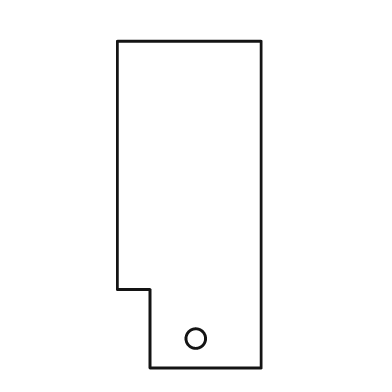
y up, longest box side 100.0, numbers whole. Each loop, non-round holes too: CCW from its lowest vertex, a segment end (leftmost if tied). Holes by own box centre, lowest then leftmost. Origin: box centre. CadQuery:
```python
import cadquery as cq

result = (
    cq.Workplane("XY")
    .moveTo(-12.0, -50.0)
    .lineTo(22.0, -50.0)
    .lineTo(22.0, 50.0)
    .lineTo(-22.0, 50.0)
    .lineTo(-22.0, -26.0)
    .lineTo(-12.0, -26.0)
    .close()
    .moveTo(2.0, -41.0)
    .circle(3.0)
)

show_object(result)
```